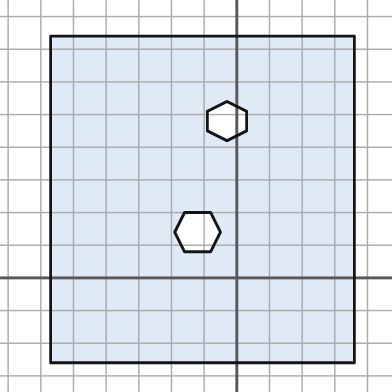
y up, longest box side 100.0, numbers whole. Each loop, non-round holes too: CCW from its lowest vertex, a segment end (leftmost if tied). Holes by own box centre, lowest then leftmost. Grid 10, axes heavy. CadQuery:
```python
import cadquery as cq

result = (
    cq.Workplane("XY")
    .moveTo(-57.0, -26.0)
    .lineTo(36.0, -26.0)
    .lineTo(36.0, 74.0)
    .lineTo(-57.0, 74.0)
    .close()
    .moveTo(-16.0, 8.0)
    .lineTo(-8.0, 8.0)
    .lineTo(-5.0, 14.0)
    .lineTo(-8.0, 20.0)
    .lineTo(-16.0, 20.0)
    .lineTo(-19.0, 14.0)
    .close()
    .moveTo(-3.0, 42.0)
    .lineTo(3.0, 45.0)
    .lineTo(3.0, 51.0)
    .lineTo(-3.0, 54.0)
    .lineTo(-9.0, 51.0)
    .lineTo(-9.0, 45.0)
    .close()
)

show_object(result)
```